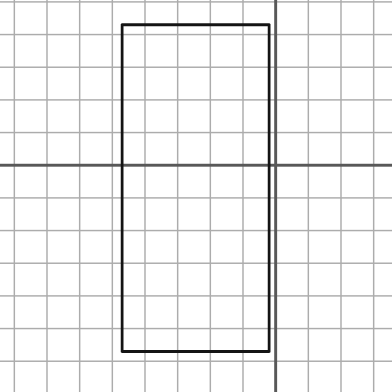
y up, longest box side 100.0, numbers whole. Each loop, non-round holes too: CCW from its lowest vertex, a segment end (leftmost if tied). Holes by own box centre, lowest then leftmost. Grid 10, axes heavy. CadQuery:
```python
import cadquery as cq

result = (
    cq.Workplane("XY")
    .moveTo(-47.0, -57.0)
    .lineTo(-2.0, -57.0)
    .lineTo(-2.0, 43.0)
    .lineTo(-47.0, 43.0)
    .close()
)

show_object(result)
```